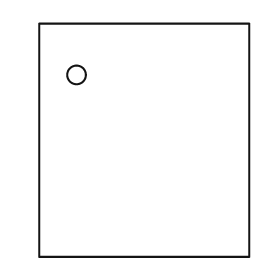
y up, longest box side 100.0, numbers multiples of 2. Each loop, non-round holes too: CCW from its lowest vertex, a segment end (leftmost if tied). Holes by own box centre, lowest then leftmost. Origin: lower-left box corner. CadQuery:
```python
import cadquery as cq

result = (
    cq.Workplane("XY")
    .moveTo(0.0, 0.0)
    .lineTo(90.0, 0.0)
    .lineTo(90.0, 100.0)
    .lineTo(0.0, 100.0)
    .close()
    .moveTo(16.0, 78.0)
    .circle(4.0)
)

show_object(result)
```